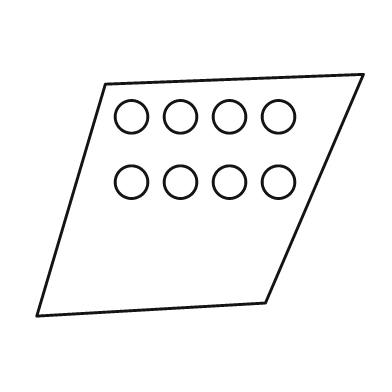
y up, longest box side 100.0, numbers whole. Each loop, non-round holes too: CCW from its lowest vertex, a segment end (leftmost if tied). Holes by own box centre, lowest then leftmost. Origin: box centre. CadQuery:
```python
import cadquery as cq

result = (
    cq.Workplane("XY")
    .moveTo(-50.0, -37.0)
    .lineTo(20.0, -33.0)
    .lineTo(50.0, 37.0)
    .lineTo(-29.0, 34.0)
    .close()
    .moveTo(-21.0, 4.0)
    .circle(5.0)
    .moveTo(-6.0, 4.0)
    .circle(5.0)
    .moveTo(9.0, 4.0)
    .circle(5.0)
    .moveTo(24.0, 4.0)
    .circle(5.0)
    .moveTo(-21.0, 24.0)
    .circle(5.0)
    .moveTo(-6.0, 24.0)
    .circle(5.0)
    .moveTo(9.0, 24.0)
    .circle(5.0)
    .moveTo(24.0, 24.0)
    .circle(5.0)
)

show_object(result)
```